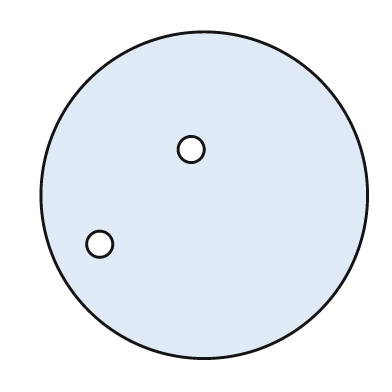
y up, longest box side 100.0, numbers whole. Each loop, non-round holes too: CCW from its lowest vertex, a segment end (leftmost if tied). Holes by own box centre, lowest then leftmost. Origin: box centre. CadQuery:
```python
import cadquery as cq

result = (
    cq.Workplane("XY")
    .moveTo(0.0, 0.0)
    .circle(50.0)
    .moveTo(-32.0, -15.0)
    .circle(4.0)
    .moveTo(-4.0, 14.0)
    .circle(4.0)
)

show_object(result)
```